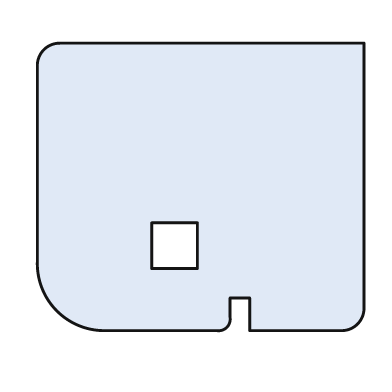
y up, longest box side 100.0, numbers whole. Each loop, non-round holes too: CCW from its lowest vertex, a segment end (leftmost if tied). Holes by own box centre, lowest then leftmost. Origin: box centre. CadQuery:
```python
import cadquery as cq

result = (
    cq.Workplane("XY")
    .moveTo(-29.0, -44.0)
    .lineTo(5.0, -44.0)
    .threePointArc((8.0, -43.0), (9.0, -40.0))
    .lineTo(9.0, -34.0)
    .lineTo(15.0, -34.0)
    .lineTo(15.0, -44.0)
    .lineTo(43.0, -44.0)
    .threePointArc((48.0, -42.0), (50.0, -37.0))
    .lineTo(50.0, 44.0)
    .lineTo(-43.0, 44.0)
    .threePointArc((-48.0, 42.0), (-50.0, 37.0))
    .lineTo(-50.0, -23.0)
    .threePointArc((-44.0, -38.0), (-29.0, -44.0))
    .close()
    .moveTo(-15.0, -25.0)
    .lineTo(-1.0, -25.0)
    .lineTo(-1.0, -11.0)
    .lineTo(-15.0, -11.0)
    .close()
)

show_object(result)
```